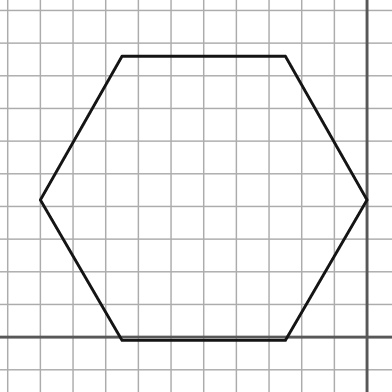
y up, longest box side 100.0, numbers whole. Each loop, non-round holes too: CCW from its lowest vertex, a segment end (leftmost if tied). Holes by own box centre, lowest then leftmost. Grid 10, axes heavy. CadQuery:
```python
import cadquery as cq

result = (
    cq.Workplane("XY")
    .moveTo(-75.0, -1.0)
    .lineTo(-25.0, -1.0)
    .lineTo(0.0, 42.0)
    .lineTo(-25.0, 86.0)
    .lineTo(-75.0, 86.0)
    .lineTo(-100.0, 42.0)
    .close()
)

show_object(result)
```